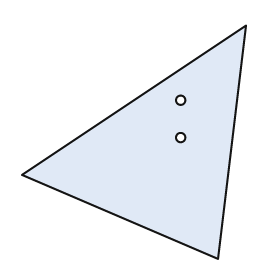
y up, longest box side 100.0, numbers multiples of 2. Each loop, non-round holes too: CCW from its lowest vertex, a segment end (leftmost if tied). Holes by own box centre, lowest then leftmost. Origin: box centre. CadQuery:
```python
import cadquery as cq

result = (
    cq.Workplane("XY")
    .moveTo(36.0, -50.0)
    .lineTo(48.0, 50.0)
    .lineTo(-48.0, -14.0)
    .close()
    .moveTo(20.0, 2.0)
    .circle(2.0)
    .moveTo(20.0, 18.0)
    .circle(2.0)
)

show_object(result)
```